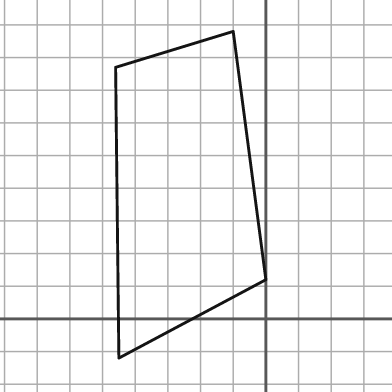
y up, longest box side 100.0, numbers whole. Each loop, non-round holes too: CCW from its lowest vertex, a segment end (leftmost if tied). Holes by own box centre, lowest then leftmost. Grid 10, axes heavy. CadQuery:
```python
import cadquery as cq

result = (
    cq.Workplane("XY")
    .moveTo(-45.0, -12.0)
    .lineTo(0.0, 12.0)
    .lineTo(-10.0, 88.0)
    .lineTo(-46.0, 77.0)
    .close()
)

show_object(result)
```